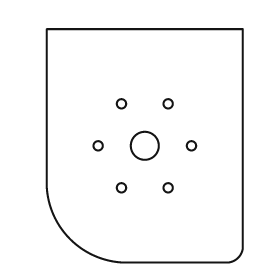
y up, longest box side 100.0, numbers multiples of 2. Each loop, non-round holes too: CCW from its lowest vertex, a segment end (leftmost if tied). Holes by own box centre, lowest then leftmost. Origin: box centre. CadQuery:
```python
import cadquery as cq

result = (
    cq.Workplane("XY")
    .moveTo(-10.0, -50.0)
    .lineTo(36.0, -50.0)
    .threePointArc((40.0, -48.0), (42.0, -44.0))
    .lineTo(42.0, 50.0)
    .lineTo(-42.0, 50.0)
    .lineTo(-42.0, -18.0)
    .threePointArc((-32.0, -40.0), (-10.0, -50.0))
    .close()
    .moveTo(-10.0, -18.0)
    .circle(2.0)
    .moveTo(10.0, -18.0)
    .circle(2.0)
    .moveTo(-20.0, 0.0)
    .circle(2.0)
    .moveTo(0.0, 0.0)
    .circle(6.0)
    .moveTo(20.0, 0.0)
    .circle(2.0)
    .moveTo(-10.0, 18.0)
    .circle(2.0)
    .moveTo(10.0, 18.0)
    .circle(2.0)
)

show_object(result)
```